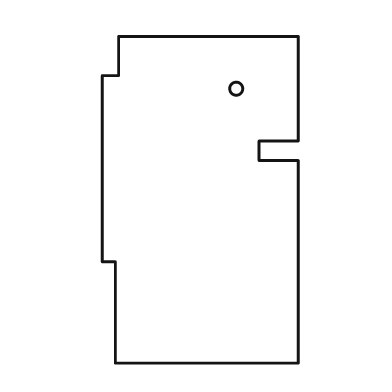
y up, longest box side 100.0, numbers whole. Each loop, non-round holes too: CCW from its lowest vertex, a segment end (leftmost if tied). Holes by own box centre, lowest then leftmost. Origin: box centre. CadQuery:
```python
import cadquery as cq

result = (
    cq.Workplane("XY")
    .moveTo(-26.0, -50.0)
    .lineTo(30.0, -50.0)
    .lineTo(30.0, 12.0)
    .lineTo(18.0, 12.0)
    .lineTo(18.0, 18.0)
    .lineTo(30.0, 18.0)
    .lineTo(30.0, 50.0)
    .lineTo(-25.0, 50.0)
    .lineTo(-25.0, 38.0)
    .lineTo(-30.0, 38.0)
    .lineTo(-30.0, -19.0)
    .lineTo(-26.0, -19.0)
    .close()
    .moveTo(11.0, 34.0)
    .circle(2.0)
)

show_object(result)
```